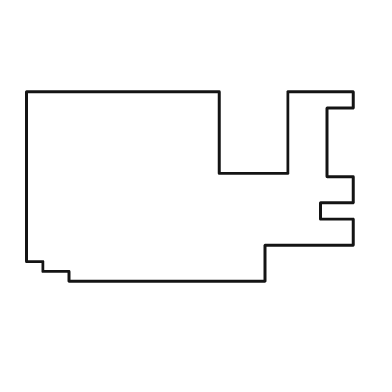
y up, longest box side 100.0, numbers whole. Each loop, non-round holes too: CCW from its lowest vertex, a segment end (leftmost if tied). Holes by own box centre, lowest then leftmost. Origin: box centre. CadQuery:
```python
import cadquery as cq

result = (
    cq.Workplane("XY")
    .moveTo(-37.0, -29.0)
    .lineTo(23.0, -29.0)
    .lineTo(23.0, -18.0)
    .lineTo(50.0, -18.0)
    .lineTo(50.0, -10.0)
    .lineTo(40.0, -10.0)
    .lineTo(40.0, -5.0)
    .lineTo(50.0, -5.0)
    .lineTo(50.0, 3.0)
    .lineTo(42.0, 3.0)
    .lineTo(42.0, 24.0)
    .lineTo(50.0, 24.0)
    .lineTo(50.0, 29.0)
    .lineTo(30.0, 29.0)
    .lineTo(30.0, 4.0)
    .lineTo(9.0, 4.0)
    .lineTo(9.0, 29.0)
    .lineTo(-50.0, 29.0)
    .lineTo(-50.0, -23.0)
    .lineTo(-45.0, -23.0)
    .lineTo(-45.0, -26.0)
    .lineTo(-37.0, -26.0)
    .close()
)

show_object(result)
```